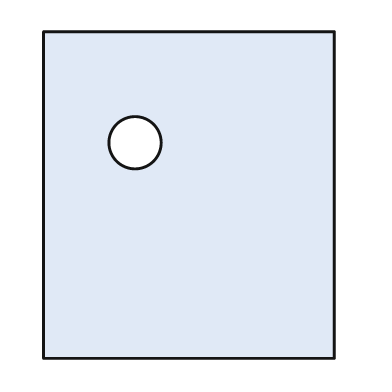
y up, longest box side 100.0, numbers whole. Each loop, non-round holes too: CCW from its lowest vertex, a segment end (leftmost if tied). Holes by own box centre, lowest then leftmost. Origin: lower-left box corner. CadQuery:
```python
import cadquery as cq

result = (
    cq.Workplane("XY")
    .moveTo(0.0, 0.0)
    .lineTo(89.0, 0.0)
    .lineTo(89.0, 100.0)
    .lineTo(0.0, 100.0)
    .close()
    .moveTo(28.0, 66.0)
    .circle(8.0)
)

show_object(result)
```